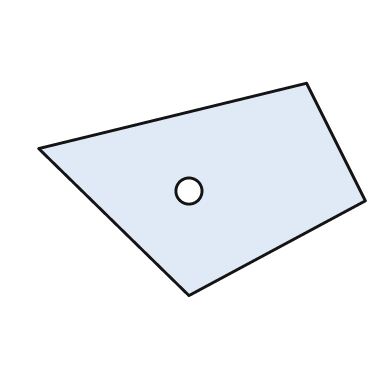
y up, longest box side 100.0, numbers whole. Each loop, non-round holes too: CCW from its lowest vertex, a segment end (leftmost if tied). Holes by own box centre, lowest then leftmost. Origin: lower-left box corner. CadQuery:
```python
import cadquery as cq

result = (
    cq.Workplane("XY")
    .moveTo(46.0, 0.0)
    .lineTo(100.0, 29.0)
    .lineTo(82.0, 65.0)
    .lineTo(0.0, 45.0)
    .close()
    .moveTo(46.0, 32.0)
    .circle(4.0)
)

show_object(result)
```